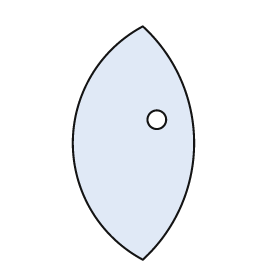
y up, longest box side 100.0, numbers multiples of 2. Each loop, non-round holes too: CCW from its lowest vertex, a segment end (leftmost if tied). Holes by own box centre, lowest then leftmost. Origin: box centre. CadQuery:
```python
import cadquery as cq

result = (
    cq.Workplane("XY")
    .moveTo(4.0, -50.0)
    .threePointArc((26.0, 0.0), (4.0, 50.0))
    .threePointArc((-26.0, 0.0), (4.0, -50.0))
    .close()
    .moveTo(10.0, 10.0)
    .circle(4.0)
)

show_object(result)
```